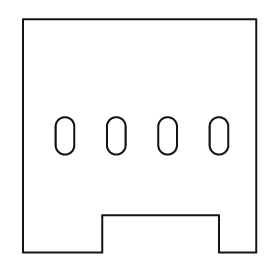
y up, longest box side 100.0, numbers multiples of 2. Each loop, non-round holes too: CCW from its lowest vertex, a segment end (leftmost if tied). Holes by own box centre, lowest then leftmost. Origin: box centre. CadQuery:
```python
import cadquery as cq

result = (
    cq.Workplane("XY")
    .moveTo(-50.0, -50.0)
    .lineTo(-16.0, -50.0)
    .lineTo(-16.0, -34.0)
    .lineTo(34.0, -34.0)
    .lineTo(34.0, -50.0)
    .lineTo(50.0, -50.0)
    .lineTo(50.0, 50.0)
    .lineTo(-50.0, 50.0)
    .close()
    .moveTo(-36.0, -4.0)
    .threePointArc((-32.0, -8.0), (-28.0, -4.0))
    .lineTo(-28.0, 4.0)
    .threePointArc((-32.0, 8.0), (-36.0, 4.0))
    .close()
    .moveTo(-14.0, -4.0)
    .threePointArc((-10.0, -8.0), (-6.0, -4.0))
    .lineTo(-6.0, 4.0)
    .threePointArc((-10.0, 8.0), (-14.0, 4.0))
    .close()
    .moveTo(8.0, -4.0)
    .threePointArc((12.0, -8.0), (16.0, -4.0))
    .lineTo(16.0, 4.0)
    .threePointArc((12.0, 8.0), (8.0, 4.0))
    .close()
    .moveTo(30.0, -4.0)
    .threePointArc((34.0, -8.0), (38.0, -4.0))
    .lineTo(38.0, 4.0)
    .threePointArc((34.0, 8.0), (30.0, 4.0))
    .close()
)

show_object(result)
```